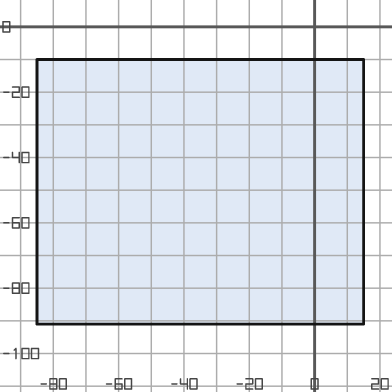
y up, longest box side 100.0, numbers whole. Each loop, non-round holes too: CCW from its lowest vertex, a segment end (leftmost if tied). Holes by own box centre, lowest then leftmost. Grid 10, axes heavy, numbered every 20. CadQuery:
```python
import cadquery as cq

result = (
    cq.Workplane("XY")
    .moveTo(-85.0, -91.0)
    .lineTo(15.0, -91.0)
    .lineTo(15.0, -10.0)
    .lineTo(-85.0, -10.0)
    .close()
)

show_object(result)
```